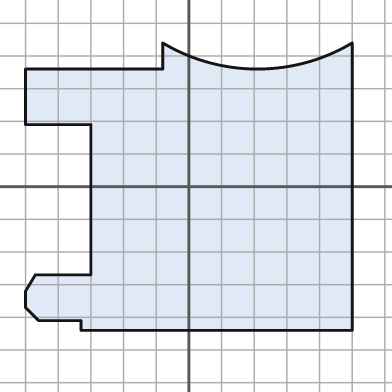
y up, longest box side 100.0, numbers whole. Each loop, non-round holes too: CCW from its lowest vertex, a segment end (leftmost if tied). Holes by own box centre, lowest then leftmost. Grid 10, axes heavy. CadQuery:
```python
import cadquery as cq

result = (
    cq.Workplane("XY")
    .moveTo(-33.0, -44.0)
    .lineTo(50.0, -44.0)
    .lineTo(50.0, 44.0)
    .threePointArc((21.0, 36.0), (-8.0, 44.0))
    .lineTo(-8.0, 36.0)
    .lineTo(-50.0, 36.0)
    .lineTo(-50.0, 19.0)
    .lineTo(-30.0, 19.0)
    .lineTo(-30.0, -27.0)
    .lineTo(-47.0, -27.0)
    .lineTo(-50.0, -32.0)
    .lineTo(-50.0, -37.0)
    .lineTo(-46.0, -41.0)
    .lineTo(-33.0, -41.0)
    .close()
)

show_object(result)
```